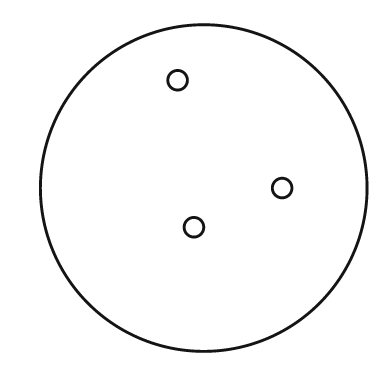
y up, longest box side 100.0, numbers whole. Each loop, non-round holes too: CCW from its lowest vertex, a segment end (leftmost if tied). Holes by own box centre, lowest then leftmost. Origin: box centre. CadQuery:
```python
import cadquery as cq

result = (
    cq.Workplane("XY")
    .moveTo(0.0, 0.0)
    .circle(50.0)
    .moveTo(-3.0, -12.0)
    .circle(3.0)
    .moveTo(24.0, 0.0)
    .circle(3.0)
    .moveTo(-8.0, 33.0)
    .circle(3.0)
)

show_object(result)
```